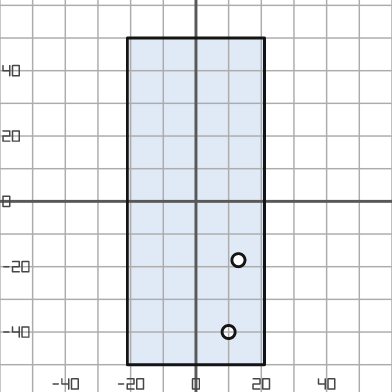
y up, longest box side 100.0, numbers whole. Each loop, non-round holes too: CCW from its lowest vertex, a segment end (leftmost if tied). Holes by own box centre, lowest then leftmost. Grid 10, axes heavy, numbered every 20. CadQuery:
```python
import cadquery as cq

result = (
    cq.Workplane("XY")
    .moveTo(-21.0, -50.0)
    .lineTo(21.0, -50.0)
    .lineTo(21.0, 50.0)
    .lineTo(-21.0, 50.0)
    .close()
    .moveTo(10.0, -40.0)
    .circle(2.0)
    .moveTo(13.0, -18.0)
    .circle(2.0)
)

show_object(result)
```